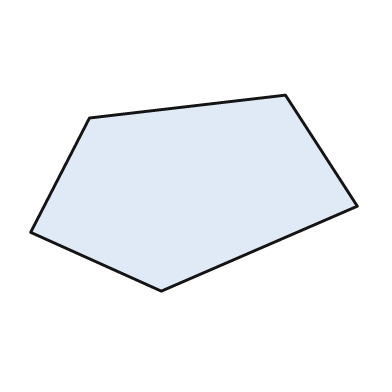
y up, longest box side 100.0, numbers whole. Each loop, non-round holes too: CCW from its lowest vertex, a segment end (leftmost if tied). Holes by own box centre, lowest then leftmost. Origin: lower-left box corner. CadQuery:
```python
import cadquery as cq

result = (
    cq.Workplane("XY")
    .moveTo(40.0, 0.0)
    .lineTo(100.0, 26.0)
    .lineTo(78.0, 60.0)
    .lineTo(18.0, 53.0)
    .lineTo(0.0, 18.0)
    .close()
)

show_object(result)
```